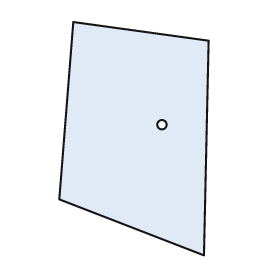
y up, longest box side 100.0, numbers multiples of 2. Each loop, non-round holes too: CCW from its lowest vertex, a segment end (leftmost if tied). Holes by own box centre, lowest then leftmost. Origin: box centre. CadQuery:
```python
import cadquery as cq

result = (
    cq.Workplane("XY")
    .moveTo(30.0, -50.0)
    .lineTo(32.0, 42.0)
    .lineTo(-26.0, 50.0)
    .lineTo(-32.0, -26.0)
    .close()
    .moveTo(12.0, 6.0)
    .circle(2.0)
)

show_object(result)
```